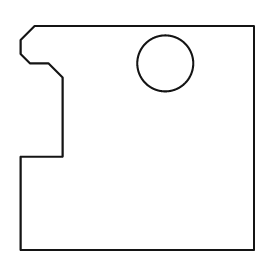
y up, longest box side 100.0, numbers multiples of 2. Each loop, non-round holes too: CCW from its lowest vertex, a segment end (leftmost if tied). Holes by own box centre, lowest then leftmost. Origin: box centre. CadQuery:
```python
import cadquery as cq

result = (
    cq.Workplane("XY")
    .moveTo(-50.0, -48.0)
    .lineTo(50.0, -48.0)
    .lineTo(50.0, 48.0)
    .lineTo(-44.0, 48.0)
    .lineTo(-50.0, 42.0)
    .lineTo(-50.0, 36.0)
    .lineTo(-46.0, 32.0)
    .lineTo(-38.0, 32.0)
    .lineTo(-32.0, 26.0)
    .lineTo(-32.0, -8.0)
    .lineTo(-50.0, -8.0)
    .close()
    .moveTo(12.0, 32.0)
    .circle(12.0)
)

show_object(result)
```